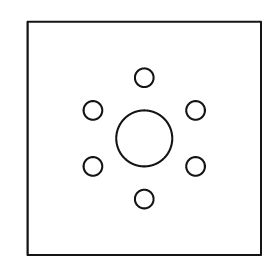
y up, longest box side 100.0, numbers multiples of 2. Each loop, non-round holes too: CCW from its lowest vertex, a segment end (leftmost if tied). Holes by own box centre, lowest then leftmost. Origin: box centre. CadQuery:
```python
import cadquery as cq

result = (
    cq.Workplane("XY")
    .moveTo(-50.0, -50.0)
    .lineTo(50.0, -50.0)
    .lineTo(50.0, 50.0)
    .lineTo(-50.0, 50.0)
    .close()
    .moveTo(0.0, -26.0)
    .circle(4.0)
    .moveTo(-22.0, -12.0)
    .circle(4.0)
    .moveTo(22.0, -12.0)
    .circle(4.0)
    .moveTo(0.0, 0.0)
    .circle(12.0)
    .moveTo(-22.0, 12.0)
    .circle(4.0)
    .moveTo(22.0, 12.0)
    .circle(4.0)
    .moveTo(0.0, 26.0)
    .circle(4.0)
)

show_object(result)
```